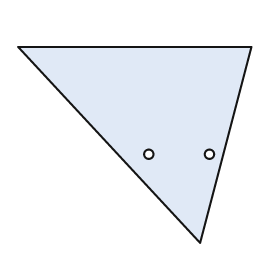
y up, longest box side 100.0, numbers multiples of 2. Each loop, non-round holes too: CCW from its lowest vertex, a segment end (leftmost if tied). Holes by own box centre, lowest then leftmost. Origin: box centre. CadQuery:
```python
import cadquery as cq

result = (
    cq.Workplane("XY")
    .moveTo(28.0, -42.0)
    .lineTo(50.0, 42.0)
    .lineTo(-50.0, 42.0)
    .close()
    .moveTo(6.0, -4.0)
    .circle(2.0)
    .moveTo(32.0, -4.0)
    .circle(2.0)
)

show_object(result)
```